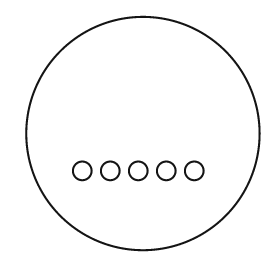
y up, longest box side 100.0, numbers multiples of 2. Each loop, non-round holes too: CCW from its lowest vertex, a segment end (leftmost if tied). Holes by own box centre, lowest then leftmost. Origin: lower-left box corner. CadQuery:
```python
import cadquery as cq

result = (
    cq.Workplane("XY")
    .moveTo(50.0, 50.0)
    .circle(50.0)
    .moveTo(24.0, 34.0)
    .circle(4.0)
    .moveTo(36.0, 34.0)
    .circle(4.0)
    .moveTo(48.0, 34.0)
    .circle(4.0)
    .moveTo(60.0, 34.0)
    .circle(4.0)
    .moveTo(72.0, 34.0)
    .circle(4.0)
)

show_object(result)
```